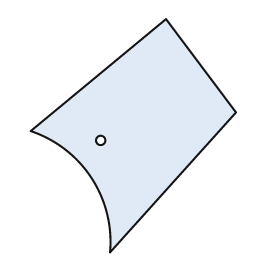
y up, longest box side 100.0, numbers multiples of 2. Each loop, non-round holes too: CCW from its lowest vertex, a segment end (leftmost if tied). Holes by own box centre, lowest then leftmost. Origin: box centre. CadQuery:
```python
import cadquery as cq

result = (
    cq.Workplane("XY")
    .moveTo(-10.0, -50.0)
    .lineTo(44.0, 10.0)
    .lineTo(14.0, 50.0)
    .lineTo(-44.0, 2.0)
    .threePointArc((-18.0, -18.0), (-10.0, -50.0))
    .close()
    .moveTo(-14.0, -2.0)
    .circle(2.0)
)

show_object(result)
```